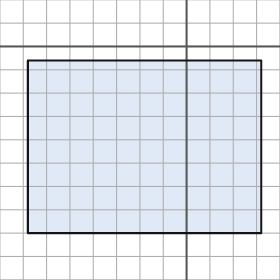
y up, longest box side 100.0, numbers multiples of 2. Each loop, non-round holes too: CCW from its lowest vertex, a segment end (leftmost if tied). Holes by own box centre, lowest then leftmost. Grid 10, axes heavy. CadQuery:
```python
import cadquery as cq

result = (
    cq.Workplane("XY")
    .moveTo(-68.0, -80.0)
    .lineTo(32.0, -80.0)
    .lineTo(32.0, -6.0)
    .lineTo(-68.0, -6.0)
    .close()
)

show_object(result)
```